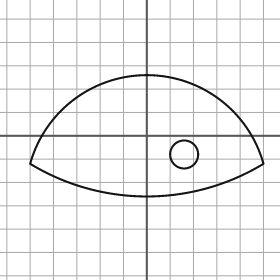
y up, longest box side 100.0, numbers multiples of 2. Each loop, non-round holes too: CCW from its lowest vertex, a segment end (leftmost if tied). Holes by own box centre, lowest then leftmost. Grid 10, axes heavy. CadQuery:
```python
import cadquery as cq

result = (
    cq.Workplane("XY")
    .moveTo(-50.0, -12.0)
    .threePointArc((0.0, -26.0), (50.0, -12.0))
    .threePointArc((0.0, 26.0), (-50.0, -12.0))
    .close()
    .moveTo(16.0, -8.0)
    .circle(6.0)
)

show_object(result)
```